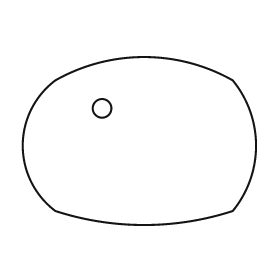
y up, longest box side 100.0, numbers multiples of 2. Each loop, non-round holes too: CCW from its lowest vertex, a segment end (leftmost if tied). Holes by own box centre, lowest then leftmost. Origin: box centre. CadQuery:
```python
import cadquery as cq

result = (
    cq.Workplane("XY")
    .moveTo(-36.0, -30.0)
    .threePointArc((2.0, -36.0), (40.0, -30.0))
    .threePointArc((50.0, -2.0), (40.0, 26.0))
    .threePointArc((2.0, 36.0), (-36.0, 26.0))
    .threePointArc((-50.0, -2.0), (-36.0, -30.0))
    .close()
    .moveTo(-16.0, 14.0)
    .circle(4.0)
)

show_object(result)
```